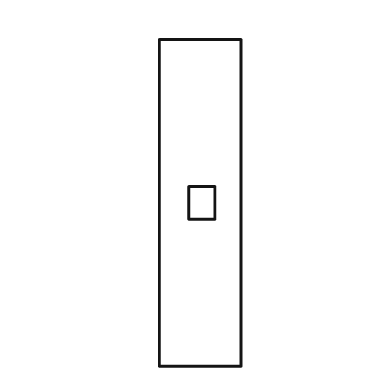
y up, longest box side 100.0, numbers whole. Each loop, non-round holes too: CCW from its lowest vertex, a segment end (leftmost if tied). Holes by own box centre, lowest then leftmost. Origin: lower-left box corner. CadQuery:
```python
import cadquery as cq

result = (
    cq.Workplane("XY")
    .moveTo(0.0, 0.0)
    .lineTo(25.0, 0.0)
    .lineTo(25.0, 100.0)
    .lineTo(0.0, 100.0)
    .close()
    .moveTo(9.0, 45.0)
    .lineTo(17.0, 45.0)
    .lineTo(17.0, 55.0)
    .lineTo(9.0, 55.0)
    .close()
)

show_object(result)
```